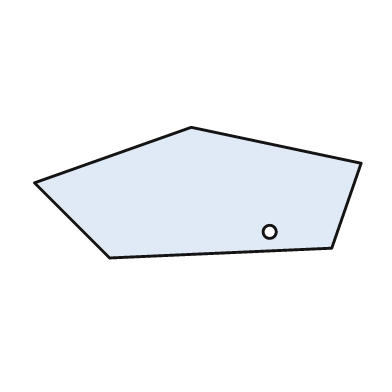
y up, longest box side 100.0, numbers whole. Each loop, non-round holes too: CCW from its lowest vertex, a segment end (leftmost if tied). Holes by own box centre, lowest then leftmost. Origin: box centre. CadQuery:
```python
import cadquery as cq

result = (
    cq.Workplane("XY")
    .moveTo(-27.0, -20.0)
    .lineTo(41.0, -17.0)
    .lineTo(50.0, 9.0)
    .lineTo(-2.0, 20.0)
    .lineTo(-50.0, 3.0)
    .close()
    .moveTo(22.0, -12.0)
    .circle(2.0)
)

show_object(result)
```